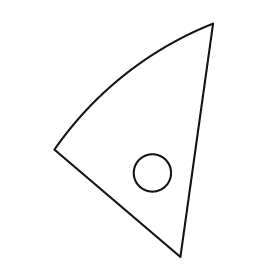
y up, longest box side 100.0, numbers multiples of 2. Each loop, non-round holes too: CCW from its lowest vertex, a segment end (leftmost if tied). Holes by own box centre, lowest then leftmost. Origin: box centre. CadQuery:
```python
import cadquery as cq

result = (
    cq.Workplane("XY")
    .moveTo(20.0, -50.0)
    .lineTo(34.0, 50.0)
    .threePointArc((-4.0, 28.0), (-34.0, -4.0))
    .close()
    .moveTo(8.0, -14.0)
    .circle(8.0)
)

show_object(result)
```